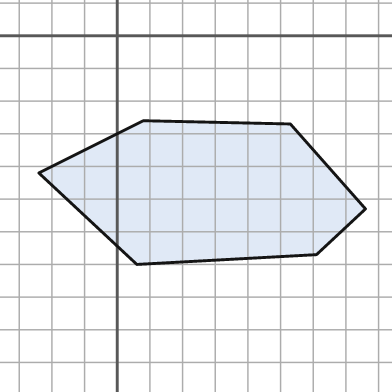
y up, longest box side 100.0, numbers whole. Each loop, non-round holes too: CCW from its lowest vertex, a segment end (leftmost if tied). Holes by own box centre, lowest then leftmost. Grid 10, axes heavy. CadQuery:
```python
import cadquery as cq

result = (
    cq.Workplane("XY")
    .moveTo(6.0, -70.0)
    .lineTo(61.0, -67.0)
    .lineTo(76.0, -53.0)
    .lineTo(53.0, -27.0)
    .lineTo(8.0, -26.0)
    .lineTo(-24.0, -42.0)
    .close()
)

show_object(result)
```